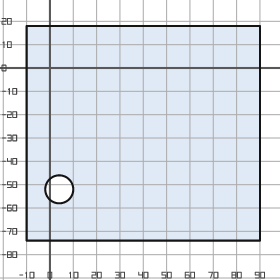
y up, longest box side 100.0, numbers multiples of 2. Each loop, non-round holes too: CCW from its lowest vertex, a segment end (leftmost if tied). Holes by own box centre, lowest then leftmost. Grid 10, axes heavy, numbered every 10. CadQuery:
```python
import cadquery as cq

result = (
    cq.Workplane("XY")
    .moveTo(-10.0, -74.0)
    .lineTo(90.0, -74.0)
    .lineTo(90.0, 18.0)
    .lineTo(-10.0, 18.0)
    .close()
    .moveTo(4.0, -52.0)
    .circle(6.0)
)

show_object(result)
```